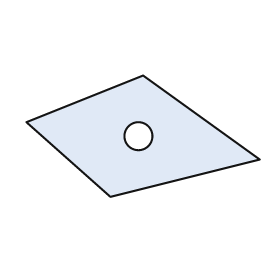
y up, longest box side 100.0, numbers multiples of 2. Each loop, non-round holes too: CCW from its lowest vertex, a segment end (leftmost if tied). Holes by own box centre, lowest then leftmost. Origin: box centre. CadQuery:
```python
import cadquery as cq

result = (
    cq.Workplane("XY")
    .moveTo(-14.0, -26.0)
    .lineTo(50.0, -10.0)
    .lineTo(0.0, 26.0)
    .lineTo(-50.0, 6.0)
    .close()
    .moveTo(-2.0, 0.0)
    .circle(6.0)
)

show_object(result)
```